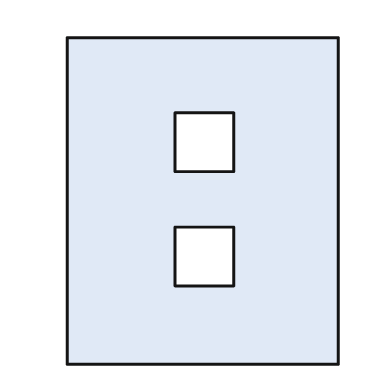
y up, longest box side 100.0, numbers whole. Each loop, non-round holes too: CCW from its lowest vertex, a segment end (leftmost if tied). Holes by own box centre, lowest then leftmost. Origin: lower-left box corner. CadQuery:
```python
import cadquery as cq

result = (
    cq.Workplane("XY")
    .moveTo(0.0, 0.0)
    .lineTo(83.0, 0.0)
    .lineTo(83.0, 100.0)
    .lineTo(0.0, 100.0)
    .close()
    .moveTo(33.0, 24.0)
    .lineTo(51.0, 24.0)
    .lineTo(51.0, 42.0)
    .lineTo(33.0, 42.0)
    .close()
    .moveTo(33.0, 59.0)
    .lineTo(51.0, 59.0)
    .lineTo(51.0, 77.0)
    .lineTo(33.0, 77.0)
    .close()
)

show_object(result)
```